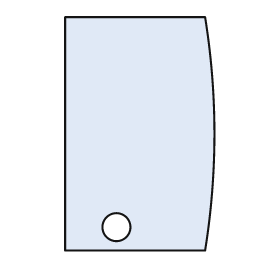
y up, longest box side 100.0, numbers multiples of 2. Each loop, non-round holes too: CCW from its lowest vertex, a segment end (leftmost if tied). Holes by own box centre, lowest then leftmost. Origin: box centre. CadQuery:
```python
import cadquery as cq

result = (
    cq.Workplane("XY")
    .moveTo(-32.0, -50.0)
    .lineTo(28.0, -50.0)
    .threePointArc((32.0, 0.0), (28.0, 50.0))
    .lineTo(-32.0, 50.0)
    .close()
    .moveTo(-10.0, -40.0)
    .circle(6.0)
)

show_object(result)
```